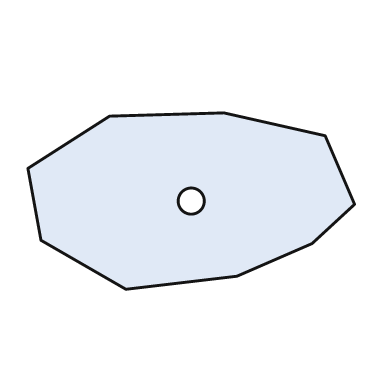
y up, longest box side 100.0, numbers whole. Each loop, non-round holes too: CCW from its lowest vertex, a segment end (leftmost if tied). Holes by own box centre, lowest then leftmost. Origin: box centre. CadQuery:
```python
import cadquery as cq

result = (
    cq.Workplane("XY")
    .moveTo(-20.0, -27.0)
    .lineTo(14.0, -23.0)
    .lineTo(37.0, -13.0)
    .lineTo(50.0, -1.0)
    .lineTo(41.0, 20.0)
    .lineTo(10.0, 27.0)
    .lineTo(-25.0, 26.0)
    .lineTo(-50.0, 10.0)
    .lineTo(-46.0, -12.0)
    .close()
    .moveTo(0.0, 0.0)
    .circle(4.0)
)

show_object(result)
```